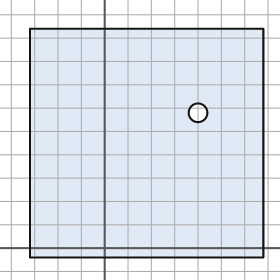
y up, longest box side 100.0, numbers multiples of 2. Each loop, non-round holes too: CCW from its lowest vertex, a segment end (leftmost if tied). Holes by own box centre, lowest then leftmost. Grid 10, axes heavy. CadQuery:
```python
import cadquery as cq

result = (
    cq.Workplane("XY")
    .moveTo(-32.0, -4.0)
    .lineTo(68.0, -4.0)
    .lineTo(68.0, 94.0)
    .lineTo(-32.0, 94.0)
    .close()
    .moveTo(40.0, 58.0)
    .circle(4.0)
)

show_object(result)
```